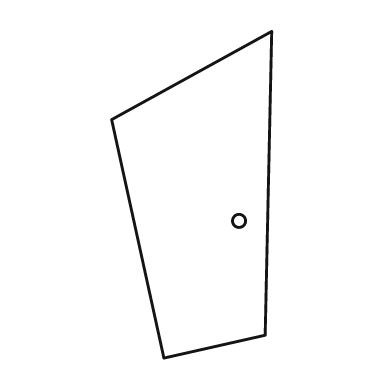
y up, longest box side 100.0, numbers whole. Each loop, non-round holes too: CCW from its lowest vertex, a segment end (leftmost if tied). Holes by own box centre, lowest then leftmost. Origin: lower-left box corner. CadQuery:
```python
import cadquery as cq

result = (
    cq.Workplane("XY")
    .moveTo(16.0, 0.0)
    .lineTo(47.0, 7.0)
    .lineTo(49.0, 100.0)
    .lineTo(0.0, 73.0)
    .close()
    .moveTo(39.0, 42.0)
    .circle(2.0)
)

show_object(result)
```